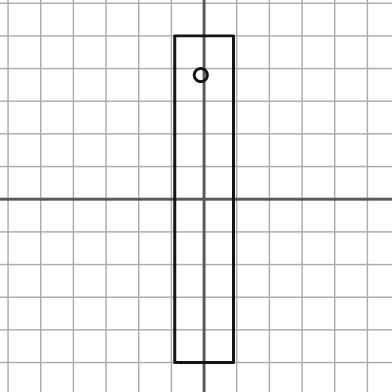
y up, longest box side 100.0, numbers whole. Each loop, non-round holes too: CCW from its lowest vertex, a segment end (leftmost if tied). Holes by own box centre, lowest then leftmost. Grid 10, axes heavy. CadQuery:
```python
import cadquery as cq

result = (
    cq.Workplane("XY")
    .moveTo(-9.0, -50.0)
    .lineTo(9.0, -50.0)
    .lineTo(9.0, 50.0)
    .lineTo(-9.0, 50.0)
    .close()
    .moveTo(-1.0, 38.0)
    .circle(2.0)
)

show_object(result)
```